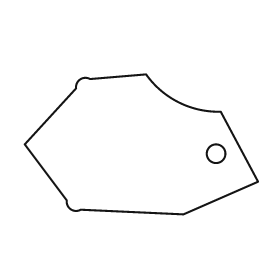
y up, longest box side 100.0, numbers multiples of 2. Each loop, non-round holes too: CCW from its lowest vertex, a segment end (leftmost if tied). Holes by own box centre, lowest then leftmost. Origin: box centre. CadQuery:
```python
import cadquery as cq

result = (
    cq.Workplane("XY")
    .moveTo(18.0, -30.0)
    .lineTo(50.0, -16.0)
    .lineTo(34.0, 14.0)
    .threePointArc((16.0, 18.0), (2.0, 30.0))
    .lineTo(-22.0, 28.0)
    .threePointArc((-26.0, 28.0), (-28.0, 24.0))
    .lineTo(-50.0, 0.0)
    .lineTo(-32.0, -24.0)
    .threePointArc((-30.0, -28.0), (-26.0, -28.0))
    .close()
    .moveTo(32.0, -4.0)
    .circle(4.0)
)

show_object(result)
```